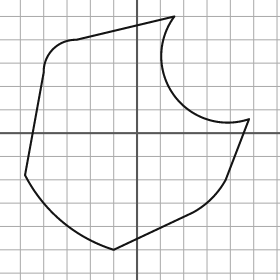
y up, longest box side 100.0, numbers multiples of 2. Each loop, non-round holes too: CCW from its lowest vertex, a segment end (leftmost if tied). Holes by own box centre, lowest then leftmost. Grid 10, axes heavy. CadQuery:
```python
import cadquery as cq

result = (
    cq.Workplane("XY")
    .moveTo(-10.0, -50.0)
    .lineTo(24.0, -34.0)
    .threePointArc((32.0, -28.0), (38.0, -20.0))
    .lineTo(48.0, 6.0)
    .threePointArc((16.0, 16.0), (16.0, 50.0))
    .lineTo(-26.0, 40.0)
    .threePointArc((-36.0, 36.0), (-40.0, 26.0))
    .lineTo(-48.0, -18.0)
    .threePointArc((-32.0, -38.0), (-10.0, -50.0))
    .close()
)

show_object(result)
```